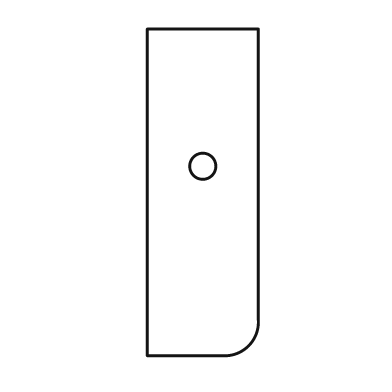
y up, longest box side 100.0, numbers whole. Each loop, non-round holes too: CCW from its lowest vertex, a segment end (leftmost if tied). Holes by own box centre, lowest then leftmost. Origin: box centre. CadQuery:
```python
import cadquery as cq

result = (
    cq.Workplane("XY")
    .moveTo(-17.0, -50.0)
    .lineTo(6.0, -50.0)
    .threePointArc((14.0, -47.0), (17.0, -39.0))
    .lineTo(17.0, 50.0)
    .lineTo(-17.0, 50.0)
    .close()
    .moveTo(0.0, 8.0)
    .circle(4.0)
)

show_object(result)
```